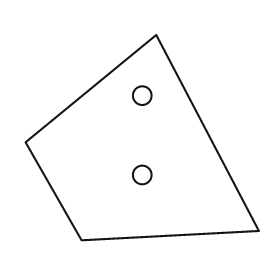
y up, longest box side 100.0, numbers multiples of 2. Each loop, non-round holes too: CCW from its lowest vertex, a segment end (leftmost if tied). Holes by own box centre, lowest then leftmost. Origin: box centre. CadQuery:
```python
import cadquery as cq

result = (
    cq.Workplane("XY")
    .moveTo(-26.0, -44.0)
    .lineTo(50.0, -40.0)
    .lineTo(6.0, 44.0)
    .lineTo(-50.0, -2.0)
    .close()
    .moveTo(0.0, -16.0)
    .circle(4.0)
    .moveTo(0.0, 18.0)
    .circle(4.0)
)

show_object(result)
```